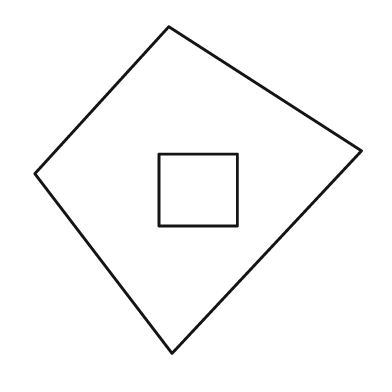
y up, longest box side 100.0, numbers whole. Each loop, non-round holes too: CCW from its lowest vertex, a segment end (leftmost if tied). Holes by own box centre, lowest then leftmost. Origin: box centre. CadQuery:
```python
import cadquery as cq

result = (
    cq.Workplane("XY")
    .moveTo(-8.0, -50.0)
    .lineTo(50.0, 12.0)
    .lineTo(-9.0, 50.0)
    .lineTo(-50.0, 5.0)
    .close()
    .moveTo(-12.0, -11.0)
    .lineTo(12.0, -11.0)
    .lineTo(12.0, 11.0)
    .lineTo(-12.0, 11.0)
    .close()
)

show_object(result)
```